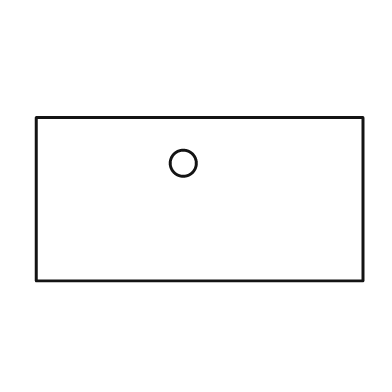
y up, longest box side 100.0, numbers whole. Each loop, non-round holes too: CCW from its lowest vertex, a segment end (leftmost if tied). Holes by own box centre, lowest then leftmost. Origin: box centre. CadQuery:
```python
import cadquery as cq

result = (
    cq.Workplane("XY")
    .moveTo(-50.0, -25.0)
    .lineTo(50.0, -25.0)
    .lineTo(50.0, 25.0)
    .lineTo(-50.0, 25.0)
    .close()
    .moveTo(-5.0, 11.0)
    .circle(4.0)
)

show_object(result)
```